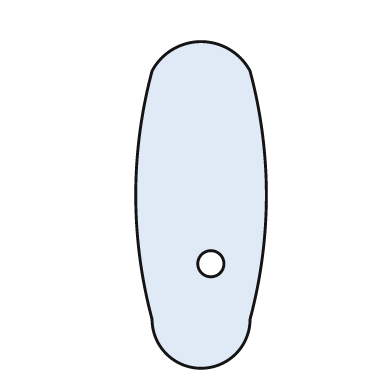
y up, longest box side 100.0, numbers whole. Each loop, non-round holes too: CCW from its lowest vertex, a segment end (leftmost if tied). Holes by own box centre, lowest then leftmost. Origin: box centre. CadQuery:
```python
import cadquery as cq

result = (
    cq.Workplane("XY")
    .moveTo(-15.0, -35.0)
    .threePointArc((0.0, -50.0), (15.0, -35.0))
    .threePointArc((20.0, 3.0), (15.0, 41.0))
    .threePointArc((0.0, 50.0), (-15.0, 41.0))
    .threePointArc((-20.0, 3.0), (-15.0, -35.0))
    .close()
    .moveTo(3.0, -18.0)
    .circle(4.0)
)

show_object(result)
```